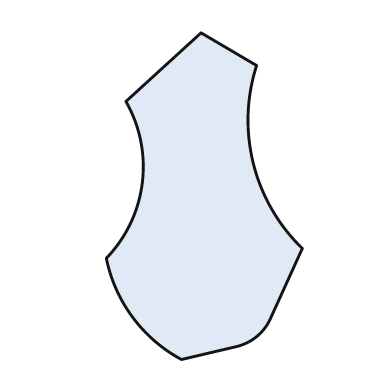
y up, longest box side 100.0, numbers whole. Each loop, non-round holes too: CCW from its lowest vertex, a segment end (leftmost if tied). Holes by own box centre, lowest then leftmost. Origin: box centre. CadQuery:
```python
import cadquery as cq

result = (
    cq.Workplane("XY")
    .moveTo(-7.0, -50.0)
    .lineTo(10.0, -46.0)
    .threePointArc((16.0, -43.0), (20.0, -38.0))
    .lineTo(30.0, -16.0)
    .threePointArc((15.0, 10.0), (16.0, 40.0))
    .lineTo(-1.0, 50.0)
    .lineTo(-24.0, 29.0)
    .threePointArc((-19.0, 4.0), (-30.0, -19.0))
    .threePointArc((-22.0, -37.0), (-7.0, -50.0))
    .close()
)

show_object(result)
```